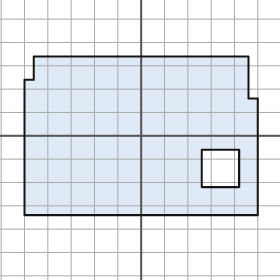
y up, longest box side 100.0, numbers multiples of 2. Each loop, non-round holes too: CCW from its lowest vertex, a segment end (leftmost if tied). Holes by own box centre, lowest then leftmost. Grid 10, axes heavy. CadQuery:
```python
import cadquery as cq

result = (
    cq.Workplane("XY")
    .moveTo(-50.0, -34.0)
    .lineTo(50.0, -34.0)
    .lineTo(50.0, 16.0)
    .lineTo(46.0, 16.0)
    .lineTo(46.0, 34.0)
    .lineTo(-46.0, 34.0)
    .lineTo(-46.0, 24.0)
    .lineTo(-50.0, 24.0)
    .close()
    .moveTo(26.0, -22.0)
    .lineTo(42.0, -22.0)
    .lineTo(42.0, -6.0)
    .lineTo(26.0, -6.0)
    .close()
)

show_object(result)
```